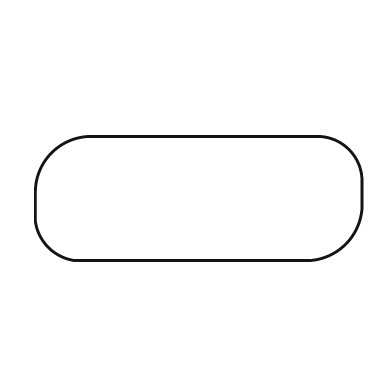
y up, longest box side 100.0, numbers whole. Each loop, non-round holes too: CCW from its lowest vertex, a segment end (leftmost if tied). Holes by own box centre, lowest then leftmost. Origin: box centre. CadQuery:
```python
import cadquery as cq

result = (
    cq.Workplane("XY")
    .moveTo(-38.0, -19.0)
    .lineTo(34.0, -19.0)
    .threePointArc((45.0, -14.0), (50.0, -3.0))
    .lineTo(50.0, 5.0)
    .threePointArc((46.0, 15.0), (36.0, 19.0))
    .lineTo(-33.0, 19.0)
    .threePointArc((-45.0, 14.0), (-50.0, 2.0))
    .lineTo(-50.0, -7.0)
    .threePointArc((-46.0, -15.0), (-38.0, -19.0))
    .close()
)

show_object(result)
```